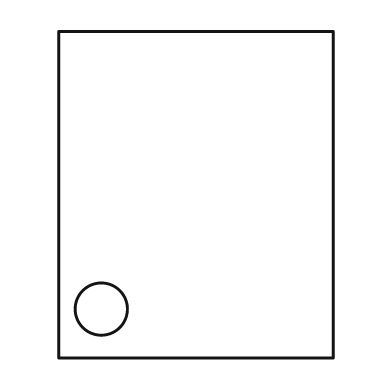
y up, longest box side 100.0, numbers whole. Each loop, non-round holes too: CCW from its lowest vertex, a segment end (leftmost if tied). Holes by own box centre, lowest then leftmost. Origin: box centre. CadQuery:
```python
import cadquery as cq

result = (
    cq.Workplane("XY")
    .moveTo(-42.0, -50.0)
    .lineTo(42.0, -50.0)
    .lineTo(42.0, 50.0)
    .lineTo(-42.0, 50.0)
    .close()
    .moveTo(-29.0, -35.0)
    .circle(8.0)
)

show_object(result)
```